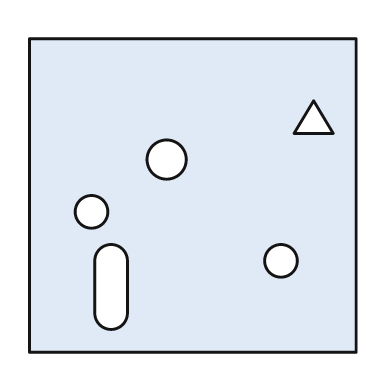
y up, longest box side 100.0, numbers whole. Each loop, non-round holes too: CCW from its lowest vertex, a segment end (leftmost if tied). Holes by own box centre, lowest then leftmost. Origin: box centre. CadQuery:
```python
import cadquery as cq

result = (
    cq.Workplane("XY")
    .moveTo(-50.0, -48.0)
    .lineTo(50.0, -48.0)
    .lineTo(50.0, 48.0)
    .lineTo(-50.0, 48.0)
    .close()
    .moveTo(-30.0, -36.0)
    .threePointArc((-25.0, -41.0), (-20.0, -36.0))
    .lineTo(-20.0, -20.0)
    .threePointArc((-25.0, -15.0), (-30.0, -20.0))
    .close()
    .moveTo(27.0, -20.0)
    .circle(5.0)
    .moveTo(-31.0, -5.0)
    .circle(5.0)
    .moveTo(-8.0, 11.0)
    .circle(6.0)
    .moveTo(31.0, 19.0)
    .lineTo(43.0, 19.0)
    .lineTo(37.0, 29.0)
    .close()
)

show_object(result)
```